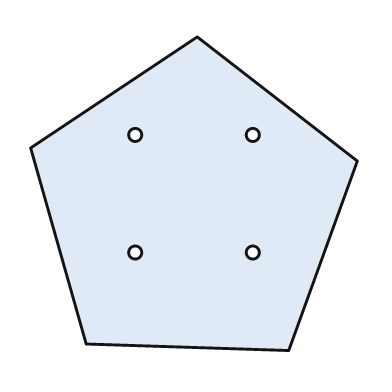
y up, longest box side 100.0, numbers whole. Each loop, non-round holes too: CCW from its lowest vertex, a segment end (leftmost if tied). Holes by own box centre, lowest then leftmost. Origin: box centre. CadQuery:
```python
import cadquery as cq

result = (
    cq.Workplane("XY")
    .moveTo(29.0, -48.0)
    .lineTo(50.0, 10.0)
    .lineTo(1.0, 48.0)
    .lineTo(-50.0, 14.0)
    .lineTo(-33.0, -46.0)
    .close()
    .moveTo(-18.0, -18.0)
    .circle(2.0)
    .moveTo(18.0, -18.0)
    .circle(2.0)
    .moveTo(-18.0, 18.0)
    .circle(2.0)
    .moveTo(18.0, 18.0)
    .circle(2.0)
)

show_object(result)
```